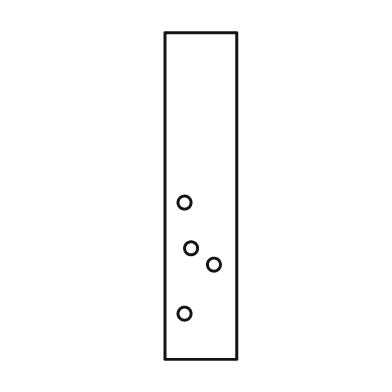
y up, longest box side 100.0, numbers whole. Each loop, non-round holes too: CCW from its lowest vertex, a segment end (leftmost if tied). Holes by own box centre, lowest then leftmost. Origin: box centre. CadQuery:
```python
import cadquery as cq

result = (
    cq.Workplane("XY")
    .moveTo(-11.0, -50.0)
    .lineTo(11.0, -50.0)
    .lineTo(11.0, 50.0)
    .lineTo(-11.0, 50.0)
    .close()
    .moveTo(-5.0, -36.0)
    .circle(2.0)
    .moveTo(4.0, -21.0)
    .circle(2.0)
    .moveTo(-3.0, -16.0)
    .circle(2.0)
    .moveTo(-5.0, -2.0)
    .circle(2.0)
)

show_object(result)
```